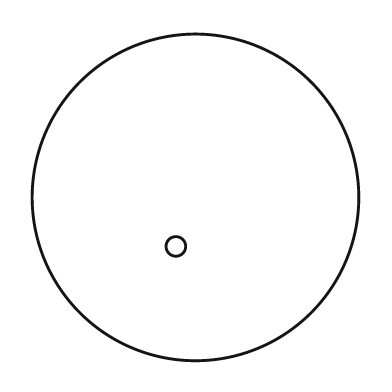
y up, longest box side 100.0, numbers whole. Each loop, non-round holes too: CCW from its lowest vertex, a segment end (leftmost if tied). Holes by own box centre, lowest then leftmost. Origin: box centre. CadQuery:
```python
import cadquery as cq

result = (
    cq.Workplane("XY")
    .moveTo(0.0, 0.0)
    .circle(50.0)
    .moveTo(-6.0, -15.0)
    .circle(3.0)
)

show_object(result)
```